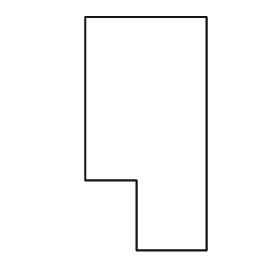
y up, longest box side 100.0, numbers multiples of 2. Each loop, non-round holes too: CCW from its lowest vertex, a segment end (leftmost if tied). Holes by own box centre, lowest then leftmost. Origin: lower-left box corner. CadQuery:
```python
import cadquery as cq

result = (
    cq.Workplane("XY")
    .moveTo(22.0, 0.0)
    .lineTo(52.0, 0.0)
    .lineTo(52.0, 100.0)
    .lineTo(0.0, 100.0)
    .lineTo(0.0, 30.0)
    .lineTo(22.0, 30.0)
    .close()
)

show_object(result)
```